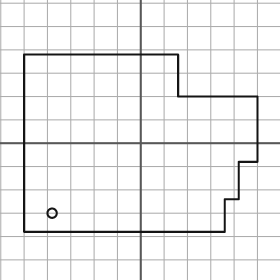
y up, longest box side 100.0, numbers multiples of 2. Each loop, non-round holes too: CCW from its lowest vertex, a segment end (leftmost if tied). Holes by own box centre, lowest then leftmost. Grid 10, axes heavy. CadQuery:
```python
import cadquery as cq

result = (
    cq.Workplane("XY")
    .moveTo(-50.0, -38.0)
    .lineTo(36.0, -38.0)
    .lineTo(36.0, -24.0)
    .lineTo(42.0, -24.0)
    .lineTo(42.0, -8.0)
    .lineTo(50.0, -8.0)
    .lineTo(50.0, 20.0)
    .lineTo(16.0, 20.0)
    .lineTo(16.0, 38.0)
    .lineTo(-50.0, 38.0)
    .close()
    .moveTo(-38.0, -30.0)
    .circle(2.0)
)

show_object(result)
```